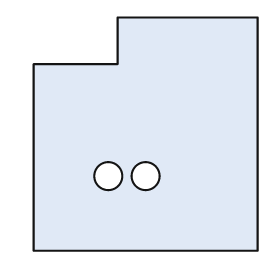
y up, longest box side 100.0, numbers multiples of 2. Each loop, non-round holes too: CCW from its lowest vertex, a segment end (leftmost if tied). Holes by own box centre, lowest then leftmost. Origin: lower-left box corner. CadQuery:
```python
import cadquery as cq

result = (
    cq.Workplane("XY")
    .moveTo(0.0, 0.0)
    .lineTo(96.0, 0.0)
    .lineTo(96.0, 100.0)
    .lineTo(36.0, 100.0)
    .lineTo(36.0, 80.0)
    .lineTo(0.0, 80.0)
    .close()
    .moveTo(32.0, 32.0)
    .circle(6.0)
    .moveTo(48.0, 32.0)
    .circle(6.0)
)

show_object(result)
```